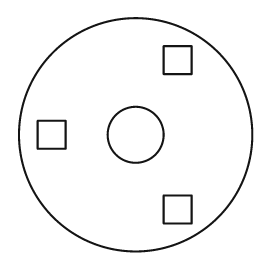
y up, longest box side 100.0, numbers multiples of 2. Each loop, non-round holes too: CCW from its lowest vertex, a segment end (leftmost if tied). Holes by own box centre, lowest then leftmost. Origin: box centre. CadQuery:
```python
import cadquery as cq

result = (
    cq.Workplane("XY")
    .moveTo(0.0, 0.0)
    .circle(50.0)
    .moveTo(12.0, -38.0)
    .lineTo(24.0, -38.0)
    .lineTo(24.0, -26.0)
    .lineTo(12.0, -26.0)
    .close()
    .moveTo(-42.0, -6.0)
    .lineTo(-30.0, -6.0)
    .lineTo(-30.0, 6.0)
    .lineTo(-42.0, 6.0)
    .close()
    .moveTo(0.0, 0.0)
    .circle(12.0)
    .moveTo(12.0, 26.0)
    .lineTo(24.0, 26.0)
    .lineTo(24.0, 38.0)
    .lineTo(12.0, 38.0)
    .close()
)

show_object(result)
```